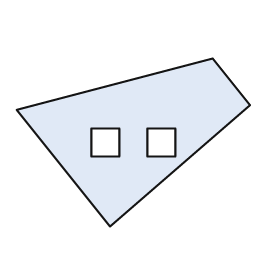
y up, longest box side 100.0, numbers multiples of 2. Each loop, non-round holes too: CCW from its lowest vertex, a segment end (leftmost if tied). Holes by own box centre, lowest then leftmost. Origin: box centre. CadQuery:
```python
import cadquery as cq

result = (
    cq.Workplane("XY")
    .moveTo(-10.0, -36.0)
    .lineTo(50.0, 16.0)
    .lineTo(34.0, 36.0)
    .lineTo(-50.0, 14.0)
    .close()
    .moveTo(-18.0, -6.0)
    .lineTo(-6.0, -6.0)
    .lineTo(-6.0, 6.0)
    .lineTo(-18.0, 6.0)
    .close()
    .moveTo(6.0, -6.0)
    .lineTo(18.0, -6.0)
    .lineTo(18.0, 6.0)
    .lineTo(6.0, 6.0)
    .close()
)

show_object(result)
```